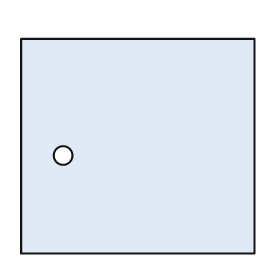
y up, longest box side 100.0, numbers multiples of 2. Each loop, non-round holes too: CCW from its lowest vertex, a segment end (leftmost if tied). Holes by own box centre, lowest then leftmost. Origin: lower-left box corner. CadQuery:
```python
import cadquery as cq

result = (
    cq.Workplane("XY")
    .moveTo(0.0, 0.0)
    .lineTo(100.0, 0.0)
    .lineTo(100.0, 92.0)
    .lineTo(0.0, 92.0)
    .close()
    .moveTo(18.0, 42.0)
    .circle(4.0)
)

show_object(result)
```